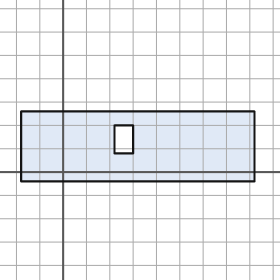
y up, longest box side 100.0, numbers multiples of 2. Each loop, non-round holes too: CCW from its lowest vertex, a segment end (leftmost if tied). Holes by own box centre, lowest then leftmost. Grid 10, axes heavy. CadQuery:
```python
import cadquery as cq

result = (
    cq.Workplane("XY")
    .moveTo(-18.0, -4.0)
    .lineTo(82.0, -4.0)
    .lineTo(82.0, 26.0)
    .lineTo(-18.0, 26.0)
    .close()
    .moveTo(22.0, 8.0)
    .lineTo(30.0, 8.0)
    .lineTo(30.0, 20.0)
    .lineTo(22.0, 20.0)
    .close()
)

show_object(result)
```